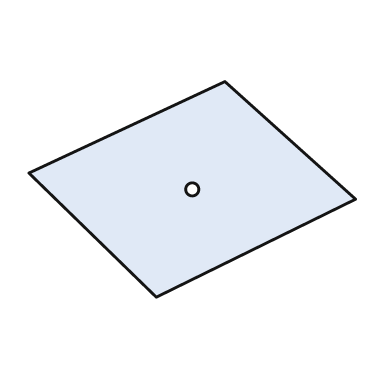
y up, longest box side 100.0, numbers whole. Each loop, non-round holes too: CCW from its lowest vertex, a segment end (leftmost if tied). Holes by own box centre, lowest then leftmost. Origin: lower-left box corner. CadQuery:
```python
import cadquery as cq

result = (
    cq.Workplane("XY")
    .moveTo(39.0, 0.0)
    .lineTo(100.0, 30.0)
    .lineTo(60.0, 66.0)
    .lineTo(0.0, 38.0)
    .close()
    .moveTo(50.0, 33.0)
    .circle(2.0)
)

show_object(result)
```